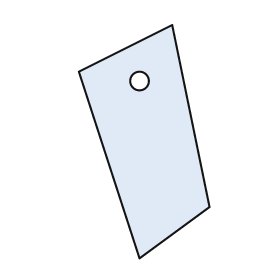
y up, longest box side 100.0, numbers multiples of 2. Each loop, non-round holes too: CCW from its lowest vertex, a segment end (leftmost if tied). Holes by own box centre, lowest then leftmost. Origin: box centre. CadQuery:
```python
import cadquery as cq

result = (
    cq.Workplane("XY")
    .moveTo(-2.0, -50.0)
    .lineTo(28.0, -28.0)
    .lineTo(12.0, 50.0)
    .lineTo(-28.0, 30.0)
    .close()
    .moveTo(-2.0, 26.0)
    .circle(4.0)
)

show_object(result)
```